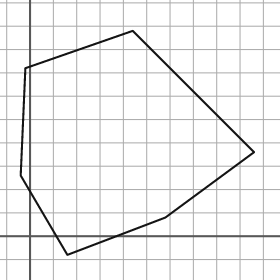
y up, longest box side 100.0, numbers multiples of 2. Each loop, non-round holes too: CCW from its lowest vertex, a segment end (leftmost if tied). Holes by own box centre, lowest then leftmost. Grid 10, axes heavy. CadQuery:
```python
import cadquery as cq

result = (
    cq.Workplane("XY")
    .moveTo(16.0, -8.0)
    .lineTo(58.0, 8.0)
    .lineTo(96.0, 36.0)
    .lineTo(44.0, 88.0)
    .lineTo(-2.0, 72.0)
    .lineTo(-4.0, 26.0)
    .close()
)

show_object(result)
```